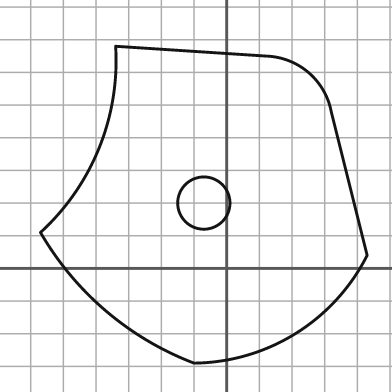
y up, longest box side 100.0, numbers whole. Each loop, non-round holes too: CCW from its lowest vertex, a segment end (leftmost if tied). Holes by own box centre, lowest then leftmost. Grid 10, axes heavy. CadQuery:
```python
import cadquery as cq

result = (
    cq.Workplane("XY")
    .moveTo(-10.0, -29.0)
    .threePointArc((21.0, -20.0), (43.0, 4.0))
    .lineTo(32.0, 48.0)
    .threePointArc((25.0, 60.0), (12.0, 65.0))
    .lineTo(-34.0, 68.0)
    .threePointArc((-39.0, 37.0), (-57.0, 11.0))
    .threePointArc((-37.0, -13.0), (-10.0, -29.0))
    .close()
    .moveTo(-7.0, 20.0)
    .circle(8.0)
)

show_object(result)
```